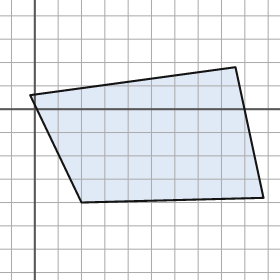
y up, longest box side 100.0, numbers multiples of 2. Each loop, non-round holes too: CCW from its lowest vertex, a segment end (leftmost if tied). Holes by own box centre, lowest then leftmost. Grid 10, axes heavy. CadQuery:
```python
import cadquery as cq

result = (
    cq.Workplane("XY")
    .moveTo(20.0, -40.0)
    .lineTo(98.0, -38.0)
    .lineTo(86.0, 18.0)
    .lineTo(-2.0, 6.0)
    .close()
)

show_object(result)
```